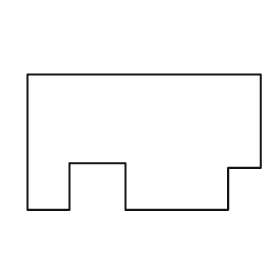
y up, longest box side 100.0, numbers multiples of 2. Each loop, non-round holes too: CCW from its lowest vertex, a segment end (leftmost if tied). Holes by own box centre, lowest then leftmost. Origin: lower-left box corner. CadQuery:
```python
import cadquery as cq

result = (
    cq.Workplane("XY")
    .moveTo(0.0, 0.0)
    .lineTo(18.0, 0.0)
    .lineTo(18.0, 20.0)
    .lineTo(42.0, 20.0)
    .lineTo(42.0, 0.0)
    .lineTo(86.0, 0.0)
    .lineTo(86.0, 18.0)
    .lineTo(100.0, 18.0)
    .lineTo(100.0, 58.0)
    .lineTo(0.0, 58.0)
    .close()
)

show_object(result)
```